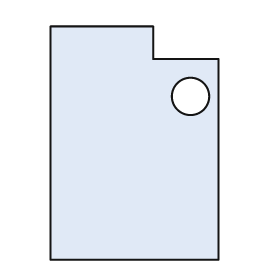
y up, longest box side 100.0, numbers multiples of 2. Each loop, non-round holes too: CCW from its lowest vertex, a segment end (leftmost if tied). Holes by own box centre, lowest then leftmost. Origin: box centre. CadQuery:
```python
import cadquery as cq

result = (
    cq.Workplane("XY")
    .moveTo(-36.0, -50.0)
    .lineTo(36.0, -50.0)
    .lineTo(36.0, 36.0)
    .lineTo(8.0, 36.0)
    .lineTo(8.0, 50.0)
    .lineTo(-36.0, 50.0)
    .close()
    .moveTo(24.0, 20.0)
    .circle(8.0)
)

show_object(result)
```